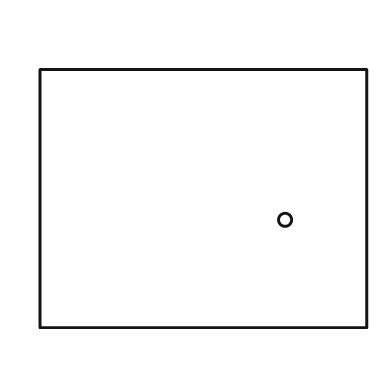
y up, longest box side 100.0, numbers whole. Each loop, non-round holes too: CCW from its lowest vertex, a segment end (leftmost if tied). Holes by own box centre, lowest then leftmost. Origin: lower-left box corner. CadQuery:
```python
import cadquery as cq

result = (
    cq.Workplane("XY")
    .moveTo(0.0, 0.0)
    .lineTo(100.0, 0.0)
    .lineTo(100.0, 79.0)
    .lineTo(0.0, 79.0)
    .close()
    .moveTo(75.0, 33.0)
    .circle(2.0)
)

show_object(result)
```